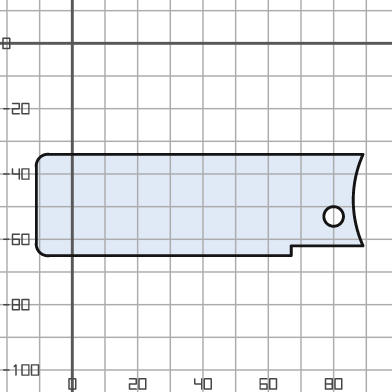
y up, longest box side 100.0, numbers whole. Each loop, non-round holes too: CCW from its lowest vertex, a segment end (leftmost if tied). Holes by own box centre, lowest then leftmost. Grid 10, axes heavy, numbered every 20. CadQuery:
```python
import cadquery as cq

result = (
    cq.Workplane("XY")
    .moveTo(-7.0, -65.0)
    .lineTo(67.0, -65.0)
    .lineTo(67.0, -62.0)
    .lineTo(89.0, -62.0)
    .threePointArc((86.0, -48.0), (89.0, -34.0))
    .lineTo(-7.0, -34.0)
    .threePointArc((-10.0, -35.0), (-11.0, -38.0))
    .lineTo(-11.0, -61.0)
    .threePointArc((-10.0, -64.0), (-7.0, -65.0))
    .close()
    .moveTo(80.0, -53.0)
    .circle(3.0)
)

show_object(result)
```